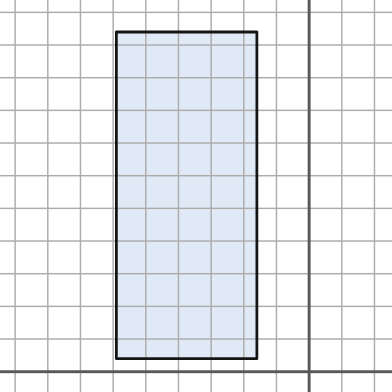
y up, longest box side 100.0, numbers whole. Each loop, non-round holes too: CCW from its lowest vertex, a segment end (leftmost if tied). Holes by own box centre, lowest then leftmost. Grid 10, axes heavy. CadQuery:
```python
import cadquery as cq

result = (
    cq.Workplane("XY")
    .moveTo(-59.0, 4.0)
    .lineTo(-16.0, 4.0)
    .lineTo(-16.0, 104.0)
    .lineTo(-59.0, 104.0)
    .close()
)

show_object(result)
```